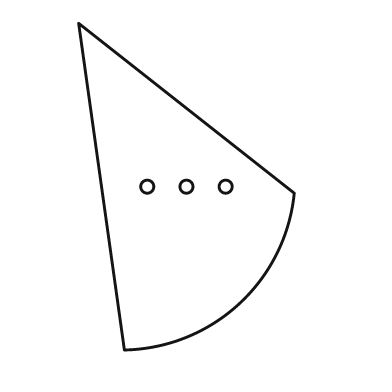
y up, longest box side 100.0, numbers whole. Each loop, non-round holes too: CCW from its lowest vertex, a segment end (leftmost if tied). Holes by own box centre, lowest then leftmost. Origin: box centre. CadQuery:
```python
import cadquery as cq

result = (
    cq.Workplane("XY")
    .moveTo(-19.0, -50.0)
    .threePointArc((16.0, -36.0), (33.0, -2.0))
    .lineTo(-33.0, 50.0)
    .close()
    .moveTo(-12.0, 0.0)
    .circle(2.0)
    .moveTo(0.0, 0.0)
    .circle(2.0)
    .moveTo(12.0, 0.0)
    .circle(2.0)
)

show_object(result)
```